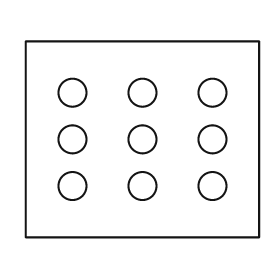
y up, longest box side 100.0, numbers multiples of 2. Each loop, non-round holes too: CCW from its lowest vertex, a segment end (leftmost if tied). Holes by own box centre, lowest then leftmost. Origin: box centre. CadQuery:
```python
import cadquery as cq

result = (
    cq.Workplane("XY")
    .moveTo(-50.0, -42.0)
    .lineTo(50.0, -42.0)
    .lineTo(50.0, 42.0)
    .lineTo(-50.0, 42.0)
    .close()
    .moveTo(-30.0, -20.0)
    .circle(6.0)
    .moveTo(0.0, -20.0)
    .circle(6.0)
    .moveTo(30.0, -20.0)
    .circle(6.0)
    .moveTo(-30.0, 0.0)
    .circle(6.0)
    .moveTo(0.0, 0.0)
    .circle(6.0)
    .moveTo(30.0, 0.0)
    .circle(6.0)
    .moveTo(-30.0, 20.0)
    .circle(6.0)
    .moveTo(0.0, 20.0)
    .circle(6.0)
    .moveTo(30.0, 20.0)
    .circle(6.0)
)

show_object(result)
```